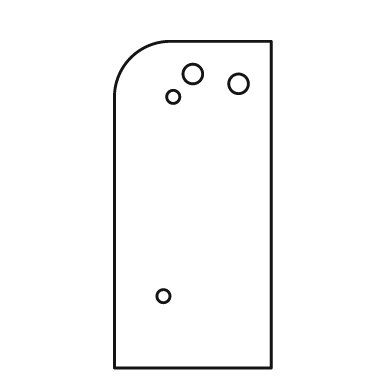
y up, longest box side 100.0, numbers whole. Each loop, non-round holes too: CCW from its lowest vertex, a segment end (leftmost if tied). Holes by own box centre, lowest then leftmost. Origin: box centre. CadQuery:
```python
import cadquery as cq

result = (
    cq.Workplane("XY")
    .moveTo(-24.0, -50.0)
    .lineTo(24.0, -50.0)
    .lineTo(24.0, 50.0)
    .lineTo(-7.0, 50.0)
    .threePointArc((-19.0, 45.0), (-24.0, 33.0))
    .close()
    .moveTo(-9.0, -28.0)
    .circle(2.0)
    .moveTo(-6.0, 33.0)
    .circle(2.0)
    .moveTo(14.0, 37.0)
    .circle(3.0)
    .moveTo(0.0, 40.0)
    .circle(3.0)
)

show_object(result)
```